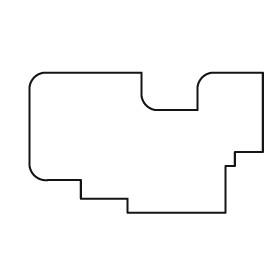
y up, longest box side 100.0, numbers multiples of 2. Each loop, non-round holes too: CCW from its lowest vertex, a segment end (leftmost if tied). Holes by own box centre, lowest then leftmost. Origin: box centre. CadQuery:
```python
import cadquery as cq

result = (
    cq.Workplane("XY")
    .moveTo(-8.0, -30.0)
    .lineTo(34.0, -30.0)
    .lineTo(34.0, -10.0)
    .lineTo(38.0, -10.0)
    .lineTo(38.0, -4.0)
    .lineTo(50.0, -4.0)
    .lineTo(50.0, 30.0)
    .lineTo(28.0, 30.0)
    .threePointArc((24.0, 28.0), (22.0, 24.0))
    .lineTo(22.0, 14.0)
    .lineTo(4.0, 14.0)
    .threePointArc((0.0, 16.0), (-2.0, 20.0))
    .lineTo(-2.0, 30.0)
    .lineTo(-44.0, 30.0)
    .threePointArc((-48.0, 28.0), (-50.0, 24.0))
    .lineTo(-50.0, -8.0)
    .threePointArc((-48.0, -14.0), (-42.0, -16.0))
    .lineTo(-28.0, -16.0)
    .lineTo(-28.0, -24.0)
    .lineTo(-8.0, -24.0)
    .close()
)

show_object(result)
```